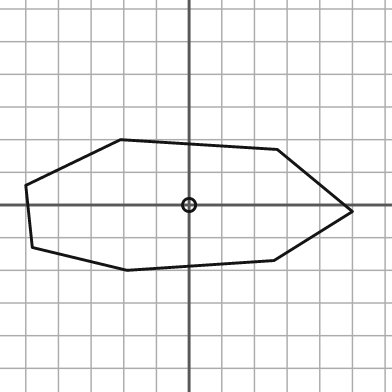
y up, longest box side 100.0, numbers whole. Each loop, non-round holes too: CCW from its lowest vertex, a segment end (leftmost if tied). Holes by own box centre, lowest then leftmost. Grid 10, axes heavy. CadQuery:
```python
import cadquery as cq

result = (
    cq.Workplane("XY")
    .moveTo(-19.0, -20.0)
    .lineTo(26.0, -17.0)
    .lineTo(50.0, -2.0)
    .lineTo(27.0, 17.0)
    .lineTo(-21.0, 20.0)
    .lineTo(-50.0, 6.0)
    .lineTo(-48.0, -13.0)
    .close()
    .moveTo(0.0, 0.0)
    .circle(2.0)
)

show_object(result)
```